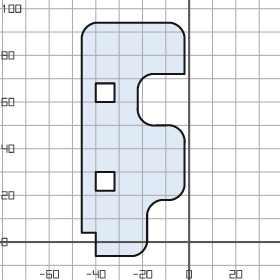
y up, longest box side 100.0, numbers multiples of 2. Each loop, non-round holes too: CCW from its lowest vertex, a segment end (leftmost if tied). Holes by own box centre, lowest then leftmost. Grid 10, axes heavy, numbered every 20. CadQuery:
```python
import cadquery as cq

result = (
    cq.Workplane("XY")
    .moveTo(-40.0, -6.0)
    .lineTo(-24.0, -6.0)
    .threePointArc((-20.0, -4.0), (-18.0, 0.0))
    .lineTo(-18.0, 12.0)
    .threePointArc((-16.0, 16.0), (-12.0, 18.0))
    .lineTo(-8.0, 18.0)
    .threePointArc((-4.0, 20.0), (-2.0, 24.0))
    .lineTo(-2.0, 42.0)
    .threePointArc((-4.0, 48.0), (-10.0, 50.0))
    .lineTo(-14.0, 50.0)
    .threePointArc((-20.0, 52.0), (-22.0, 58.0))
    .lineTo(-22.0, 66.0)
    .threePointArc((-20.0, 70.0), (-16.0, 72.0))
    .lineTo(-2.0, 72.0)
    .lineTo(-2.0, 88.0)
    .threePointArc((-4.0, 92.0), (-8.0, 94.0))
    .lineTo(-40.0, 94.0)
    .threePointArc((-44.0, 92.0), (-46.0, 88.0))
    .lineTo(-46.0, 4.0)
    .lineTo(-40.0, 4.0)
    .close()
    .moveTo(-40.0, 22.0)
    .lineTo(-32.0, 22.0)
    .lineTo(-32.0, 30.0)
    .lineTo(-40.0, 30.0)
    .close()
    .moveTo(-40.0, 60.0)
    .lineTo(-32.0, 60.0)
    .lineTo(-32.0, 68.0)
    .lineTo(-40.0, 68.0)
    .close()
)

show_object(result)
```